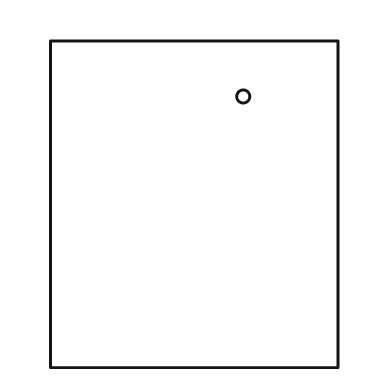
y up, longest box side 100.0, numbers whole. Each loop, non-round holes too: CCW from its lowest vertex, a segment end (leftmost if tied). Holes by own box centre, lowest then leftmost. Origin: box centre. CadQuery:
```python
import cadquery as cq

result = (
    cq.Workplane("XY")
    .moveTo(-44.0, -50.0)
    .lineTo(44.0, -50.0)
    .lineTo(44.0, 50.0)
    .lineTo(-44.0, 50.0)
    .close()
    .moveTo(15.0, 33.0)
    .circle(2.0)
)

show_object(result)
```